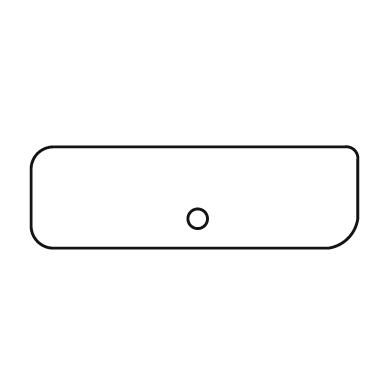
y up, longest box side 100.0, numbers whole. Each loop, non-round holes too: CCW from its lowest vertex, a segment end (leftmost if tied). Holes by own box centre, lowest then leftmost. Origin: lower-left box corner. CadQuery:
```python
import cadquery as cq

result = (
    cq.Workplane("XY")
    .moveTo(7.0, 0.0)
    .lineTo(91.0, 0.0)
    .threePointArc((97.0, 3.0), (100.0, 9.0))
    .lineTo(100.0, 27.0)
    .threePointArc((99.0, 30.0), (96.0, 31.0))
    .lineTo(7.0, 31.0)
    .threePointArc((2.0, 29.0), (0.0, 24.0))
    .lineTo(0.0, 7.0)
    .threePointArc((2.0, 2.0), (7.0, 0.0))
    .close()
    .moveTo(51.0, 9.0)
    .circle(3.0)
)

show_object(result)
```